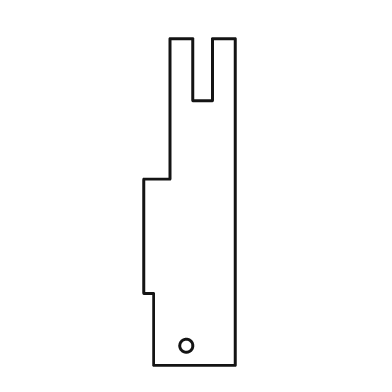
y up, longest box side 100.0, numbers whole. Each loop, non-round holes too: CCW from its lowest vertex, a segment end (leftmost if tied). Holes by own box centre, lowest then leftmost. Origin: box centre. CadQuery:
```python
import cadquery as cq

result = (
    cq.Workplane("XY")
    .moveTo(-11.0, -50.0)
    .lineTo(14.0, -50.0)
    .lineTo(14.0, 50.0)
    .lineTo(7.0, 50.0)
    .lineTo(7.0, 31.0)
    .lineTo(1.0, 31.0)
    .lineTo(1.0, 50.0)
    .lineTo(-6.0, 50.0)
    .lineTo(-6.0, 7.0)
    .lineTo(-14.0, 7.0)
    .lineTo(-14.0, -28.0)
    .lineTo(-11.0, -28.0)
    .close()
    .moveTo(-1.0, -44.0)
    .circle(2.0)
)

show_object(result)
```